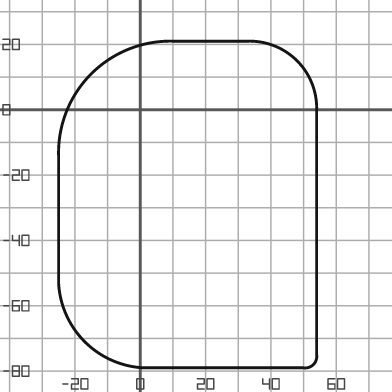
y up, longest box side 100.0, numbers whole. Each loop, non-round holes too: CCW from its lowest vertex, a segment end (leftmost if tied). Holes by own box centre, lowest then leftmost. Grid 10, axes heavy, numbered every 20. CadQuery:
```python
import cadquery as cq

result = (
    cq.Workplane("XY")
    .moveTo(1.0, -79.0)
    .lineTo(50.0, -79.0)
    .threePointArc((53.0, -78.0), (54.0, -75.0))
    .lineTo(54.0, 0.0)
    .threePointArc((48.0, 15.0), (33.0, 21.0))
    .lineTo(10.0, 21.0)
    .threePointArc((-15.0, 11.0), (-25.0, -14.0))
    .lineTo(-25.0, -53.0)
    .threePointArc((-17.0, -71.0), (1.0, -79.0))
    .close()
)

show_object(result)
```